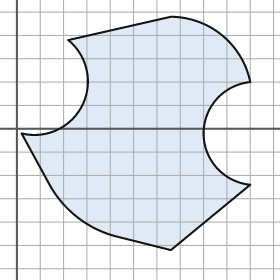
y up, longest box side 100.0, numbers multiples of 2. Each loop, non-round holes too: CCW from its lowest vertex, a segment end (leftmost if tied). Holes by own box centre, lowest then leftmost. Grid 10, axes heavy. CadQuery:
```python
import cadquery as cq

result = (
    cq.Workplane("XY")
    .moveTo(66.0, -52.0)
    .lineTo(100.0, -24.0)
    .threePointArc((80.0, -2.0), (100.0, 20.0))
    .threePointArc((88.0, 40.0), (66.0, 48.0))
    .lineTo(22.0, 38.0)
    .threePointArc((28.0, 10.0), (2.0, -2.0))
    .lineTo(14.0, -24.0)
    .threePointArc((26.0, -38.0), (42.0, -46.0))
    .close()
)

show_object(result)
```